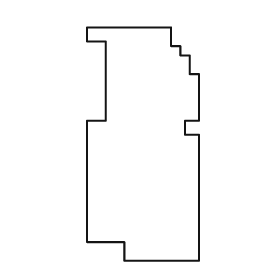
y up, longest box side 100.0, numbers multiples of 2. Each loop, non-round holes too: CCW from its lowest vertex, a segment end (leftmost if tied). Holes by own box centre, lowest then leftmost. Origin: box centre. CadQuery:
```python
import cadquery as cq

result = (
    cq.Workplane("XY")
    .moveTo(-8.0, -50.0)
    .lineTo(24.0, -50.0)
    .lineTo(24.0, 4.0)
    .lineTo(18.0, 4.0)
    .lineTo(18.0, 10.0)
    .lineTo(24.0, 10.0)
    .lineTo(24.0, 30.0)
    .lineTo(20.0, 30.0)
    .lineTo(20.0, 38.0)
    .lineTo(16.0, 38.0)
    .lineTo(16.0, 42.0)
    .lineTo(12.0, 42.0)
    .lineTo(12.0, 50.0)
    .lineTo(-24.0, 50.0)
    .lineTo(-24.0, 44.0)
    .lineTo(-16.0, 44.0)
    .lineTo(-16.0, 10.0)
    .lineTo(-24.0, 10.0)
    .lineTo(-24.0, -42.0)
    .lineTo(-8.0, -42.0)
    .close()
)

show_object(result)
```